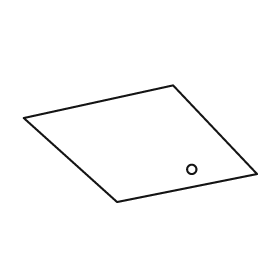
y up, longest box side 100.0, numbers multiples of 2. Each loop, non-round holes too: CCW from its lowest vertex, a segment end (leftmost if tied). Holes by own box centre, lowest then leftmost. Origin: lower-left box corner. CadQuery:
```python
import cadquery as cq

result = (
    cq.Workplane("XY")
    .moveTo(40.0, 0.0)
    .lineTo(100.0, 12.0)
    .lineTo(64.0, 50.0)
    .lineTo(0.0, 36.0)
    .close()
    .moveTo(72.0, 14.0)
    .circle(2.0)
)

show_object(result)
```